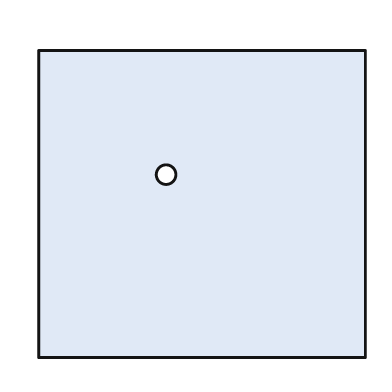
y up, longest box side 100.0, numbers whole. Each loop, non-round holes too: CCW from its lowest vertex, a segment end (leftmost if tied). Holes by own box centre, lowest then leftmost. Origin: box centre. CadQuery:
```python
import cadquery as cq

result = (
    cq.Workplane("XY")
    .moveTo(-50.0, -47.0)
    .lineTo(50.0, -47.0)
    .lineTo(50.0, 47.0)
    .lineTo(-50.0, 47.0)
    .close()
    .moveTo(-11.0, 9.0)
    .circle(3.0)
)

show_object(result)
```